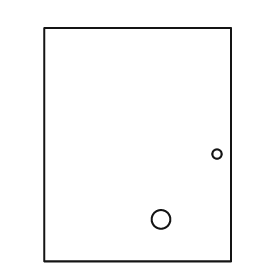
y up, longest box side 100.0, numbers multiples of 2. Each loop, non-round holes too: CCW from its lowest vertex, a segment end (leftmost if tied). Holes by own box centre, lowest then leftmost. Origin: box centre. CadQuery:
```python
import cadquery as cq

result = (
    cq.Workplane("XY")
    .moveTo(-40.0, -50.0)
    .lineTo(40.0, -50.0)
    .lineTo(40.0, 50.0)
    .lineTo(-40.0, 50.0)
    .close()
    .moveTo(10.0, -32.0)
    .circle(4.0)
    .moveTo(34.0, -4.0)
    .circle(2.0)
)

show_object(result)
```